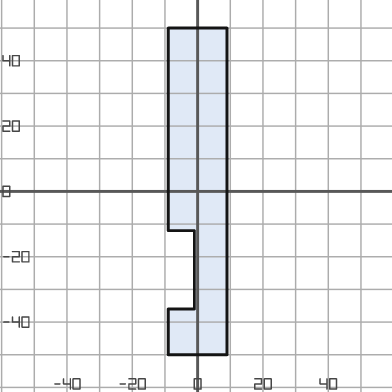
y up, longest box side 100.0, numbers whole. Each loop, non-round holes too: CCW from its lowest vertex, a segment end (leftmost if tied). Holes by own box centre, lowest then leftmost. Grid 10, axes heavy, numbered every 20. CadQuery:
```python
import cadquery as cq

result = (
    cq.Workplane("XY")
    .moveTo(-9.0, -50.0)
    .lineTo(9.0, -50.0)
    .lineTo(9.0, 50.0)
    .lineTo(-9.0, 50.0)
    .lineTo(-9.0, -12.0)
    .lineTo(-1.0, -12.0)
    .lineTo(-1.0, -36.0)
    .lineTo(-9.0, -36.0)
    .close()
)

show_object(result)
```